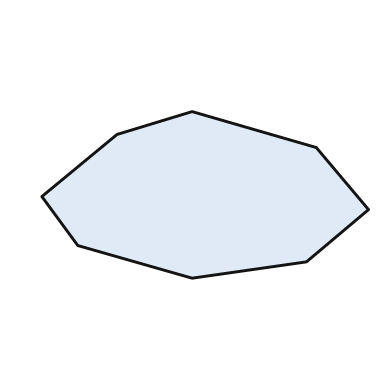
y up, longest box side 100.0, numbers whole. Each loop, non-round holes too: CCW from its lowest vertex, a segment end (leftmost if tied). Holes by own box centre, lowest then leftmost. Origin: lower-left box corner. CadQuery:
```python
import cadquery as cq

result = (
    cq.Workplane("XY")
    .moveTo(46.0, 0.0)
    .lineTo(81.0, 5.0)
    .lineTo(100.0, 21.0)
    .lineTo(84.0, 40.0)
    .lineTo(46.0, 51.0)
    .lineTo(23.0, 44.0)
    .lineTo(0.0, 25.0)
    .lineTo(11.0, 10.0)
    .close()
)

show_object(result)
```